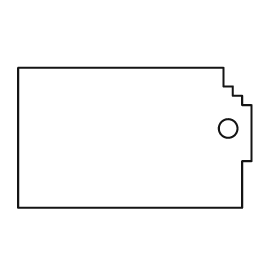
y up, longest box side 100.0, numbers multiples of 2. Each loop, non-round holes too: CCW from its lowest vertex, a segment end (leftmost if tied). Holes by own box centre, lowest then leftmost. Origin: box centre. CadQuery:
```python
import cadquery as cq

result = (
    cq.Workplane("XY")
    .moveTo(-50.0, -30.0)
    .lineTo(46.0, -30.0)
    .lineTo(46.0, -10.0)
    .lineTo(50.0, -10.0)
    .lineTo(50.0, 14.0)
    .lineTo(46.0, 14.0)
    .lineTo(46.0, 18.0)
    .lineTo(42.0, 18.0)
    .lineTo(42.0, 22.0)
    .lineTo(38.0, 22.0)
    .lineTo(38.0, 30.0)
    .lineTo(-50.0, 30.0)
    .close()
    .moveTo(40.0, 4.0)
    .circle(4.0)
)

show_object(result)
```